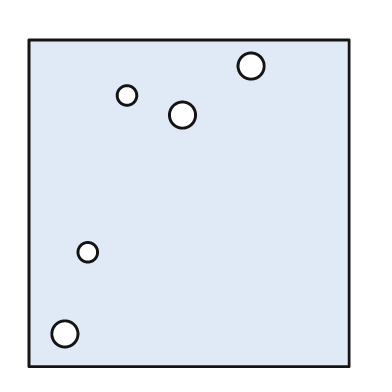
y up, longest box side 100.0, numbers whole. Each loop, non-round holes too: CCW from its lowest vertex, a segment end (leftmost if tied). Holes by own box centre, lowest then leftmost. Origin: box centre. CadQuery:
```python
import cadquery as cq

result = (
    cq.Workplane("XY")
    .moveTo(-49.0, -50.0)
    .lineTo(49.0, -50.0)
    .lineTo(49.0, 50.0)
    .lineTo(-49.0, 50.0)
    .close()
    .moveTo(-38.0, -40.0)
    .circle(4.0)
    .moveTo(-31.0, -15.0)
    .circle(3.0)
    .moveTo(-2.0, 27.0)
    .circle(4.0)
    .moveTo(-19.0, 33.0)
    .circle(3.0)
    .moveTo(19.0, 42.0)
    .circle(4.0)
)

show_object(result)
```